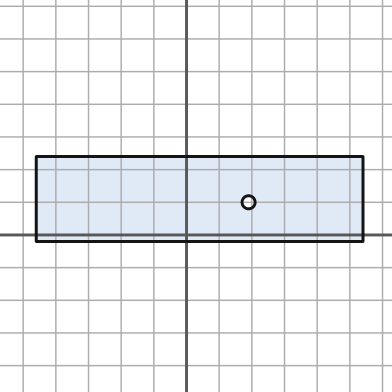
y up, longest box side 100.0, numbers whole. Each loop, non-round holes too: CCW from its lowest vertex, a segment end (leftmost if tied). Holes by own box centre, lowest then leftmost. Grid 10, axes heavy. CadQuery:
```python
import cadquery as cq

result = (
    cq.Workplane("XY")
    .moveTo(-46.0, -2.0)
    .lineTo(54.0, -2.0)
    .lineTo(54.0, 24.0)
    .lineTo(-46.0, 24.0)
    .close()
    .moveTo(19.0, 10.0)
    .circle(2.0)
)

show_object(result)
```